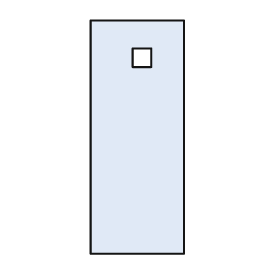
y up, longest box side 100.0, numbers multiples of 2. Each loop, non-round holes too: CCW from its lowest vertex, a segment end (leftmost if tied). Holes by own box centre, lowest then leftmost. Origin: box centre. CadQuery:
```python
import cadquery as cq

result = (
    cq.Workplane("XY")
    .moveTo(-20.0, -50.0)
    .lineTo(20.0, -50.0)
    .lineTo(20.0, 50.0)
    .lineTo(-20.0, 50.0)
    .close()
    .moveTo(-2.0, 30.0)
    .lineTo(6.0, 30.0)
    .lineTo(6.0, 38.0)
    .lineTo(-2.0, 38.0)
    .close()
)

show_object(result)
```